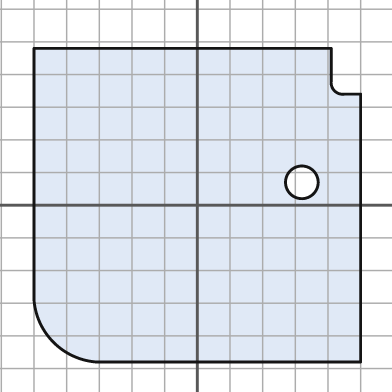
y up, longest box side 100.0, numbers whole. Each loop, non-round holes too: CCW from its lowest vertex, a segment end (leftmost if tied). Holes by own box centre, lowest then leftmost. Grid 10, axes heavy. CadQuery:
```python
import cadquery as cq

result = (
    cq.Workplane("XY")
    .moveTo(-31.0, -48.0)
    .lineTo(50.0, -48.0)
    .lineTo(50.0, 34.0)
    .lineTo(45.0, 34.0)
    .threePointArc((42.0, 35.0), (41.0, 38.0))
    .lineTo(41.0, 48.0)
    .lineTo(-50.0, 48.0)
    .lineTo(-50.0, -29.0)
    .threePointArc((-44.0, -42.0), (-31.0, -48.0))
    .close()
    .moveTo(32.0, 7.0)
    .circle(5.0)
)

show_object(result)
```